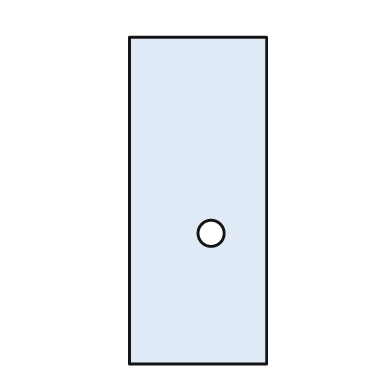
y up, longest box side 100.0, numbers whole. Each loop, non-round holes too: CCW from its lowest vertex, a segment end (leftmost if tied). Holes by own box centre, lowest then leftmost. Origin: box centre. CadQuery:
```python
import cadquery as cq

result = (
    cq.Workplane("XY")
    .moveTo(-21.0, -50.0)
    .lineTo(21.0, -50.0)
    .lineTo(21.0, 50.0)
    .lineTo(-21.0, 50.0)
    .close()
    .moveTo(4.0, -10.0)
    .circle(4.0)
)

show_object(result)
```